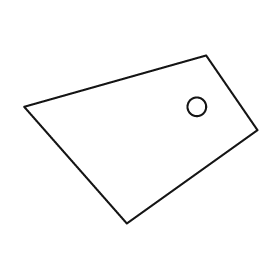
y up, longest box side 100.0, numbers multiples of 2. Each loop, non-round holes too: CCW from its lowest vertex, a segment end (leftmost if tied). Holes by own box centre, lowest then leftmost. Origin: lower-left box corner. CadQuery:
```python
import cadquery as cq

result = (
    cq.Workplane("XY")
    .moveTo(44.0, 0.0)
    .lineTo(100.0, 40.0)
    .lineTo(78.0, 72.0)
    .lineTo(0.0, 50.0)
    .close()
    .moveTo(74.0, 50.0)
    .circle(4.0)
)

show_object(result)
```